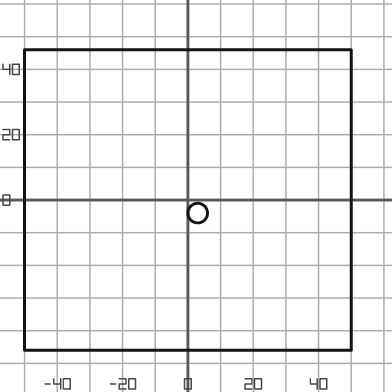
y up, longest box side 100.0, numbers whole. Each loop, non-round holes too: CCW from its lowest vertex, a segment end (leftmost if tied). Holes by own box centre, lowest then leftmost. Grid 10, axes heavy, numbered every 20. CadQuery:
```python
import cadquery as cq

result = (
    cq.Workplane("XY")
    .moveTo(-50.0, -46.0)
    .lineTo(50.0, -46.0)
    .lineTo(50.0, 46.0)
    .lineTo(-50.0, 46.0)
    .close()
    .moveTo(3.0, -4.0)
    .circle(3.0)
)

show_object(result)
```